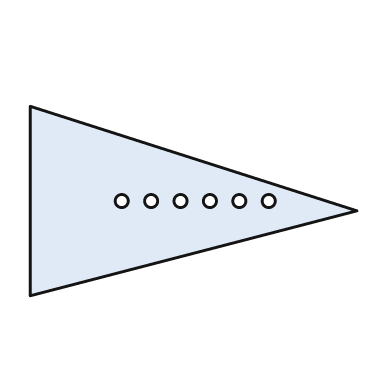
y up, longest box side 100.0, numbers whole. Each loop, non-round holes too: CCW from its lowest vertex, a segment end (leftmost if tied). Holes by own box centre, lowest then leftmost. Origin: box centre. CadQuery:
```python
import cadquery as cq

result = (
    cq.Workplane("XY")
    .moveTo(-50.0, -29.0)
    .lineTo(50.0, -3.0)
    .lineTo(-50.0, 29.0)
    .close()
    .moveTo(-22.0, 0.0)
    .circle(2.0)
    .moveTo(-13.0, 0.0)
    .circle(2.0)
    .moveTo(-4.0, 0.0)
    .circle(2.0)
    .moveTo(5.0, 0.0)
    .circle(2.0)
    .moveTo(14.0, 0.0)
    .circle(2.0)
    .moveTo(23.0, 0.0)
    .circle(2.0)
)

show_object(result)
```